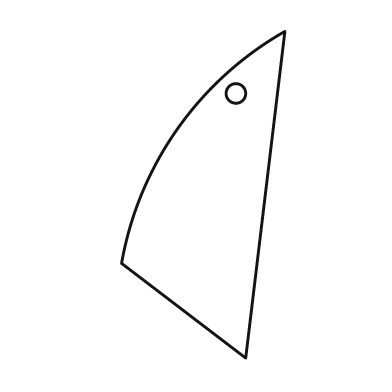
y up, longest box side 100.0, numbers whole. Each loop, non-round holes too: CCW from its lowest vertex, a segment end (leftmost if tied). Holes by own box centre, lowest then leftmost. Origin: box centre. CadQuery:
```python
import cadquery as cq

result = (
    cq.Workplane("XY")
    .moveTo(13.0, -50.0)
    .lineTo(25.0, 50.0)
    .threePointArc((-8.0, 20.0), (-25.0, -21.0))
    .close()
    .moveTo(10.0, 31.0)
    .circle(3.0)
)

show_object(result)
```